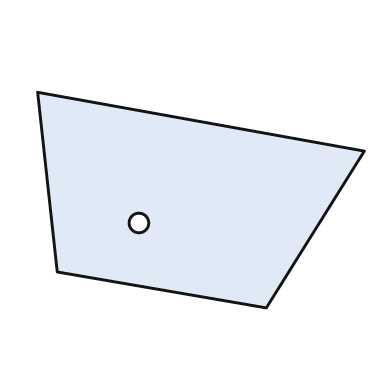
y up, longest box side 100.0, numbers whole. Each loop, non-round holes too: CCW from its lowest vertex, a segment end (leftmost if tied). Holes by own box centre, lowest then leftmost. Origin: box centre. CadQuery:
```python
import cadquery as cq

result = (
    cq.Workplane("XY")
    .moveTo(20.0, -33.0)
    .lineTo(50.0, 15.0)
    .lineTo(-50.0, 33.0)
    .lineTo(-44.0, -22.0)
    .close()
    .moveTo(-19.0, -7.0)
    .circle(3.0)
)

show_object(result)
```